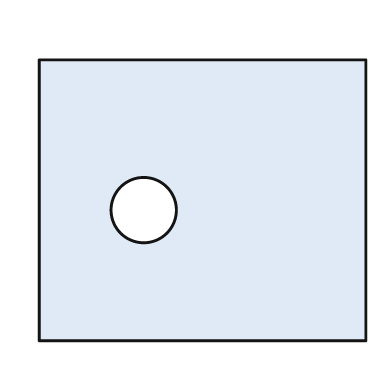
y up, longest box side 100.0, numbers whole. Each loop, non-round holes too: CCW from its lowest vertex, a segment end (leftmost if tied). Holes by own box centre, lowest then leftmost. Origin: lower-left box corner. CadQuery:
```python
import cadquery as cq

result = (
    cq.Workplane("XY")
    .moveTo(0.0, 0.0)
    .lineTo(100.0, 0.0)
    .lineTo(100.0, 86.0)
    .lineTo(0.0, 86.0)
    .close()
    .moveTo(32.0, 40.0)
    .circle(10.0)
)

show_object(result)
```